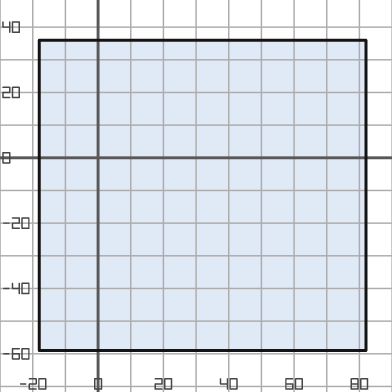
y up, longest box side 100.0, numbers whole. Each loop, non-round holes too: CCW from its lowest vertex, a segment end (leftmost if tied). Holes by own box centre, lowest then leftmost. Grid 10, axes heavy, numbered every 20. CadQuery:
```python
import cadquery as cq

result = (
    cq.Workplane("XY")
    .moveTo(-18.0, -59.0)
    .lineTo(82.0, -59.0)
    .lineTo(82.0, 36.0)
    .lineTo(-18.0, 36.0)
    .close()
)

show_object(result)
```